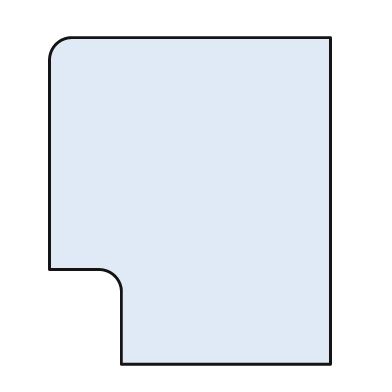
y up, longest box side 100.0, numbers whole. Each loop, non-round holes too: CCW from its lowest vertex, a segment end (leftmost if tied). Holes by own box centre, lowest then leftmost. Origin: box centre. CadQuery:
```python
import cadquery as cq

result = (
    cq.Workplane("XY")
    .moveTo(-21.0, -50.0)
    .lineTo(43.0, -50.0)
    .lineTo(43.0, 50.0)
    .lineTo(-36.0, 50.0)
    .threePointArc((-41.0, 48.0), (-43.0, 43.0))
    .lineTo(-43.0, -21.0)
    .lineTo(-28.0, -21.0)
    .threePointArc((-23.0, -23.0), (-21.0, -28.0))
    .close()
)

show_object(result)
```